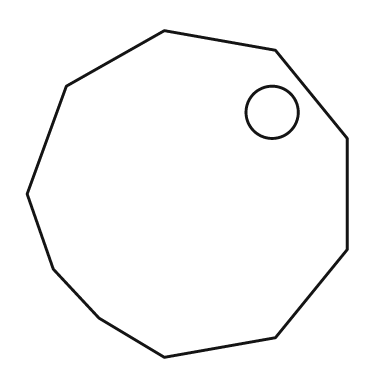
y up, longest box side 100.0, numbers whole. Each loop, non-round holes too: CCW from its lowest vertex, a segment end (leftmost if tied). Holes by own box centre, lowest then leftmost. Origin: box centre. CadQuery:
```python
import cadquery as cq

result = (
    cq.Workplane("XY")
    .moveTo(-7.0, -50.0)
    .lineTo(27.0, -44.0)
    .lineTo(49.0, -17.0)
    .lineTo(49.0, 17.0)
    .lineTo(27.0, 44.0)
    .lineTo(-7.0, 50.0)
    .lineTo(-37.0, 33.0)
    .lineTo(-49.0, 0.0)
    .lineTo(-41.0, -23.0)
    .lineTo(-27.0, -38.0)
    .close()
    .moveTo(26.0, 25.0)
    .circle(8.0)
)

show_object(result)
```